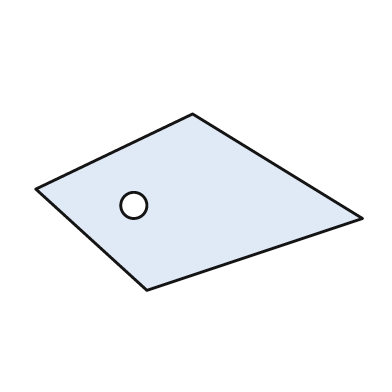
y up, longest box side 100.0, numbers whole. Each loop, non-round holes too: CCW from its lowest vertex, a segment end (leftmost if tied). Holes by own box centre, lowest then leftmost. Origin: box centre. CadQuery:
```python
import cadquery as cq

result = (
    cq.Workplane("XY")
    .moveTo(-16.0, -27.0)
    .lineTo(50.0, -5.0)
    .lineTo(-2.0, 27.0)
    .lineTo(-50.0, 4.0)
    .close()
    .moveTo(-20.0, -1.0)
    .circle(4.0)
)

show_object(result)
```